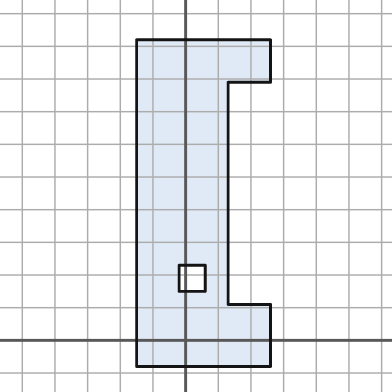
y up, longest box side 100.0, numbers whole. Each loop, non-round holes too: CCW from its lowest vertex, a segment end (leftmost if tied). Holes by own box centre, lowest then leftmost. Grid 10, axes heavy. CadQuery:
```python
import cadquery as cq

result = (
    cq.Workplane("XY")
    .moveTo(-15.0, -8.0)
    .lineTo(26.0, -8.0)
    .lineTo(26.0, 11.0)
    .lineTo(13.0, 11.0)
    .lineTo(13.0, 79.0)
    .lineTo(26.0, 79.0)
    .lineTo(26.0, 92.0)
    .lineTo(-15.0, 92.0)
    .close()
    .moveTo(-2.0, 15.0)
    .lineTo(6.0, 15.0)
    .lineTo(6.0, 23.0)
    .lineTo(-2.0, 23.0)
    .close()
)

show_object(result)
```